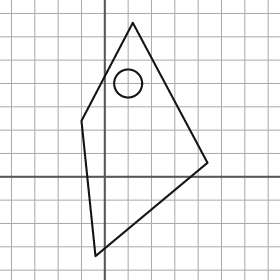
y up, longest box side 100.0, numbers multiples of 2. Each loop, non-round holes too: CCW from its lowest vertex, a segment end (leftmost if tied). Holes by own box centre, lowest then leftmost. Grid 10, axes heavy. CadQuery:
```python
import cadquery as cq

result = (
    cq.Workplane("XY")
    .moveTo(-4.0, -34.0)
    .lineTo(44.0, 6.0)
    .lineTo(12.0, 66.0)
    .lineTo(-10.0, 24.0)
    .close()
    .moveTo(10.0, 40.0)
    .circle(6.0)
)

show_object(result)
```